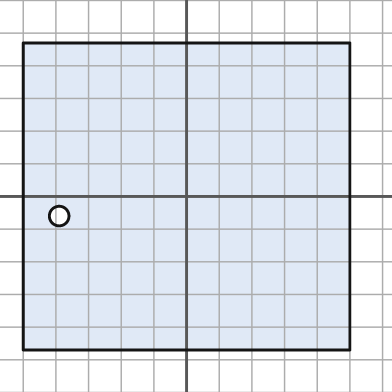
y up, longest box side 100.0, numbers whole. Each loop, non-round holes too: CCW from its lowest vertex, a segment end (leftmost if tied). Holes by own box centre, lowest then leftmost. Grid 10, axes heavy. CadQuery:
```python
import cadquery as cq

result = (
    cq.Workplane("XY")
    .moveTo(-50.0, -47.0)
    .lineTo(50.0, -47.0)
    .lineTo(50.0, 47.0)
    .lineTo(-50.0, 47.0)
    .close()
    .moveTo(-39.0, -6.0)
    .circle(3.0)
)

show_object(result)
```